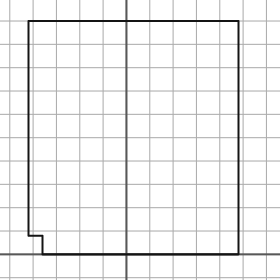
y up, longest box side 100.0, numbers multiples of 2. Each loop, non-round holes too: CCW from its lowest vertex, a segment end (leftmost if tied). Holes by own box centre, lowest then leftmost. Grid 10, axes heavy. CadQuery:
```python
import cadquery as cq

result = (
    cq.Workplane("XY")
    .moveTo(-36.0, 0.0)
    .lineTo(48.0, 0.0)
    .lineTo(48.0, 100.0)
    .lineTo(-42.0, 100.0)
    .lineTo(-42.0, 8.0)
    .lineTo(-36.0, 8.0)
    .close()
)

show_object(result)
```